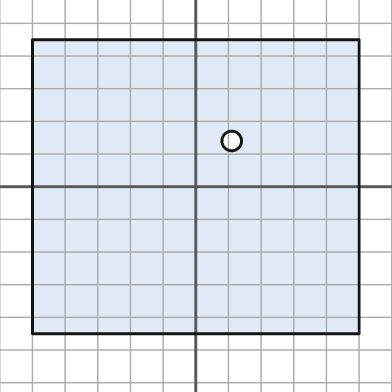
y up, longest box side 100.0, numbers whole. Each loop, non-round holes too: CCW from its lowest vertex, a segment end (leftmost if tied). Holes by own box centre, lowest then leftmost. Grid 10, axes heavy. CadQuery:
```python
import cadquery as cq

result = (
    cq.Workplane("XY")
    .moveTo(-50.0, -45.0)
    .lineTo(50.0, -45.0)
    .lineTo(50.0, 45.0)
    .lineTo(-50.0, 45.0)
    .close()
    .moveTo(11.0, 14.0)
    .circle(3.0)
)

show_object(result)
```